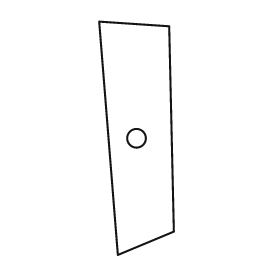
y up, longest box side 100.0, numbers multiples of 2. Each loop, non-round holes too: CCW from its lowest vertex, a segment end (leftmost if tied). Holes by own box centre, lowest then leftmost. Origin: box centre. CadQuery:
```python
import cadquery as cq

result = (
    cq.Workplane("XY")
    .moveTo(-8.0, -50.0)
    .lineTo(16.0, -40.0)
    .lineTo(14.0, 48.0)
    .lineTo(-16.0, 50.0)
    .close()
    .moveTo(0.0, 0.0)
    .circle(4.0)
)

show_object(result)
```